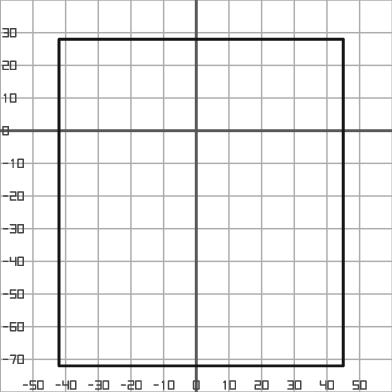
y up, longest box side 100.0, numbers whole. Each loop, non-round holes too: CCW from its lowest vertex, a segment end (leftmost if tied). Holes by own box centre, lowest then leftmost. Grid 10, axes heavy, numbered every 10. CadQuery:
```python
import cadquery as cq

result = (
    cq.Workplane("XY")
    .moveTo(-42.0, -72.0)
    .lineTo(45.0, -72.0)
    .lineTo(45.0, 28.0)
    .lineTo(-42.0, 28.0)
    .close()
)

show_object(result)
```